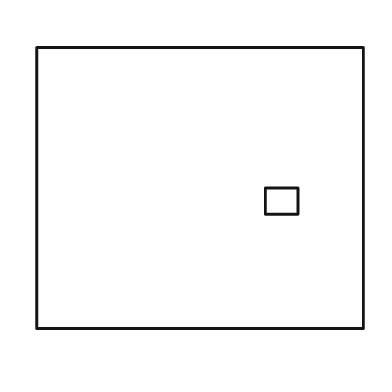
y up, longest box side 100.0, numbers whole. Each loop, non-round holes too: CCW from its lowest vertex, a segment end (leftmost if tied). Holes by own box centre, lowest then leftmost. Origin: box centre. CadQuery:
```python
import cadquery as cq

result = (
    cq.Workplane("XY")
    .moveTo(-50.0, -43.0)
    .lineTo(50.0, -43.0)
    .lineTo(50.0, 43.0)
    .lineTo(-50.0, 43.0)
    .close()
    .moveTo(20.0, -8.0)
    .lineTo(30.0, -8.0)
    .lineTo(30.0, 0.0)
    .lineTo(20.0, 0.0)
    .close()
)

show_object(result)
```